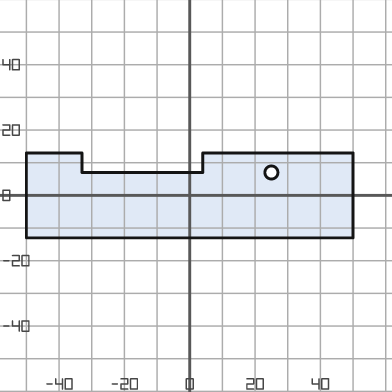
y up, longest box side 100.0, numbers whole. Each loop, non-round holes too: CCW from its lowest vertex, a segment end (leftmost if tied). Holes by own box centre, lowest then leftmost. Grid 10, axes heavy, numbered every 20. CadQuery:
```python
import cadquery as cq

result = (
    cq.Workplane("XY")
    .moveTo(-50.0, -13.0)
    .lineTo(50.0, -13.0)
    .lineTo(50.0, 13.0)
    .lineTo(4.0, 13.0)
    .lineTo(4.0, 7.0)
    .lineTo(-33.0, 7.0)
    .lineTo(-33.0, 13.0)
    .lineTo(-50.0, 13.0)
    .close()
    .moveTo(25.0, 7.0)
    .circle(2.0)
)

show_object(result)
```